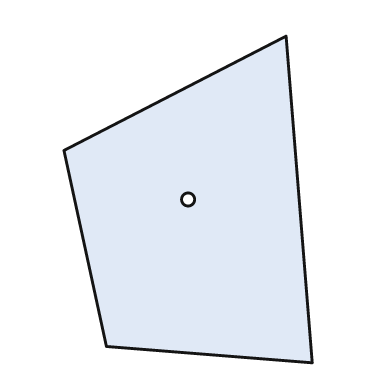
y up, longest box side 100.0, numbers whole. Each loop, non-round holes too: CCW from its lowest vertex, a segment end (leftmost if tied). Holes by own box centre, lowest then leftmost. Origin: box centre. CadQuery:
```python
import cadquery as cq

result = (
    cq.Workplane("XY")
    .moveTo(38.0, -50.0)
    .lineTo(30.0, 50.0)
    .lineTo(-38.0, 15.0)
    .lineTo(-25.0, -45.0)
    .close()
    .moveTo(0.0, 0.0)
    .circle(2.0)
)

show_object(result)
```